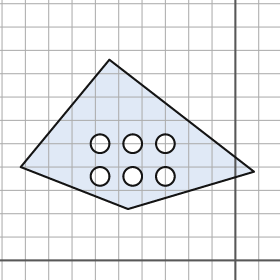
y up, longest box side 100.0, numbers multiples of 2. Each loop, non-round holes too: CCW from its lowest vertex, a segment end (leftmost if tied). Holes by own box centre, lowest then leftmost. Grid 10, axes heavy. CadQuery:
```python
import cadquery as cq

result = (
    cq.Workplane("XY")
    .moveTo(-46.0, 22.0)
    .lineTo(8.0, 38.0)
    .lineTo(-54.0, 86.0)
    .lineTo(-92.0, 40.0)
    .close()
    .moveTo(-58.0, 36.0)
    .circle(4.0)
    .moveTo(-44.0, 36.0)
    .circle(4.0)
    .moveTo(-30.0, 36.0)
    .circle(4.0)
    .moveTo(-58.0, 50.0)
    .circle(4.0)
    .moveTo(-44.0, 50.0)
    .circle(4.0)
    .moveTo(-30.0, 50.0)
    .circle(4.0)
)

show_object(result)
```